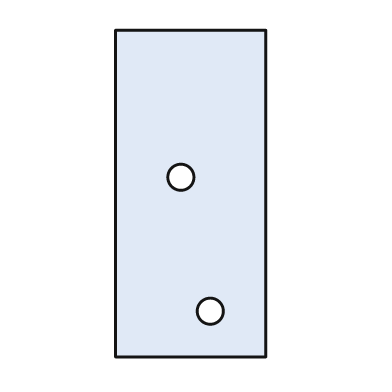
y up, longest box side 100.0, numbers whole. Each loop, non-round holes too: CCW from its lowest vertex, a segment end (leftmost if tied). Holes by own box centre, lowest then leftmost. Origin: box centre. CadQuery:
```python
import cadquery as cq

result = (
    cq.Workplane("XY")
    .moveTo(-23.0, -50.0)
    .lineTo(23.0, -50.0)
    .lineTo(23.0, 50.0)
    .lineTo(-23.0, 50.0)
    .close()
    .moveTo(6.0, -36.0)
    .circle(4.0)
    .moveTo(-3.0, 5.0)
    .circle(4.0)
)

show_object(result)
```